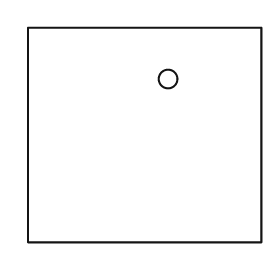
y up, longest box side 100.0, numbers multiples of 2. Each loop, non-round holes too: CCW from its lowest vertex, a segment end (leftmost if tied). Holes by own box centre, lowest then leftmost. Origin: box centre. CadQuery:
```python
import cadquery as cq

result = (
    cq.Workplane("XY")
    .moveTo(-50.0, -46.0)
    .lineTo(50.0, -46.0)
    .lineTo(50.0, 46.0)
    .lineTo(-50.0, 46.0)
    .close()
    .moveTo(10.0, 24.0)
    .circle(4.0)
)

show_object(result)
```